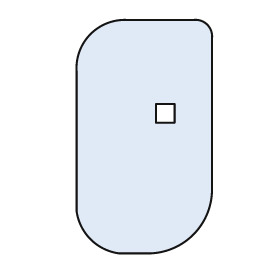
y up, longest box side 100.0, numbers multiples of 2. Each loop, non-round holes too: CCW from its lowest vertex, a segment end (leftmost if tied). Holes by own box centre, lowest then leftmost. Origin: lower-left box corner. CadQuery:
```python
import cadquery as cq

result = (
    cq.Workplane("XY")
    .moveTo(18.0, 0.0)
    .lineTo(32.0, 0.0)
    .threePointArc((50.0, 8.0), (58.0, 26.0))
    .lineTo(58.0, 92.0)
    .threePointArc((56.0, 98.0), (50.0, 100.0))
    .lineTo(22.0, 100.0)
    .threePointArc((6.0, 94.0), (0.0, 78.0))
    .lineTo(0.0, 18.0)
    .threePointArc((6.0, 6.0), (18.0, 0.0))
    .close()
    .moveTo(34.0, 56.0)
    .lineTo(42.0, 56.0)
    .lineTo(42.0, 64.0)
    .lineTo(34.0, 64.0)
    .close()
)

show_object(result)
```